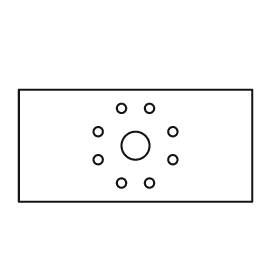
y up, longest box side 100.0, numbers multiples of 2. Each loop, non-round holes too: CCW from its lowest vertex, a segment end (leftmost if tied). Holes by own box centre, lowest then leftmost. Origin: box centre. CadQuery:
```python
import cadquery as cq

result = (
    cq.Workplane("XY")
    .moveTo(-50.0, -24.0)
    .lineTo(50.0, -24.0)
    .lineTo(50.0, 24.0)
    .lineTo(-50.0, 24.0)
    .close()
    .moveTo(-6.0, -16.0)
    .circle(2.0)
    .moveTo(6.0, -16.0)
    .circle(2.0)
    .moveTo(-16.0, -6.0)
    .circle(2.0)
    .moveTo(16.0, -6.0)
    .circle(2.0)
    .moveTo(0.0, 0.0)
    .circle(6.0)
    .moveTo(-16.0, 6.0)
    .circle(2.0)
    .moveTo(16.0, 6.0)
    .circle(2.0)
    .moveTo(-6.0, 16.0)
    .circle(2.0)
    .moveTo(6.0, 16.0)
    .circle(2.0)
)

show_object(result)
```